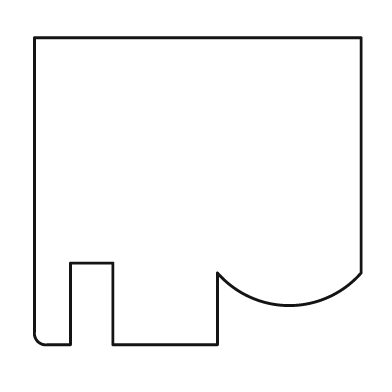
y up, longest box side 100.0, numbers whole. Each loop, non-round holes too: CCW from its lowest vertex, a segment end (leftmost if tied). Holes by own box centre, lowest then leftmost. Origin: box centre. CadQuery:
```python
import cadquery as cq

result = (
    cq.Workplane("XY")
    .moveTo(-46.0, -47.0)
    .lineTo(-39.0, -47.0)
    .lineTo(-39.0, -22.0)
    .lineTo(-26.0, -22.0)
    .lineTo(-26.0, -47.0)
    .lineTo(6.0, -47.0)
    .lineTo(6.0, -25.0)
    .threePointArc((28.0, -35.0), (50.0, -25.0))
    .lineTo(50.0, 47.0)
    .lineTo(-50.0, 47.0)
    .lineTo(-50.0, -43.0)
    .threePointArc((-49.0, -46.0), (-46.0, -47.0))
    .close()
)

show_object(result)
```